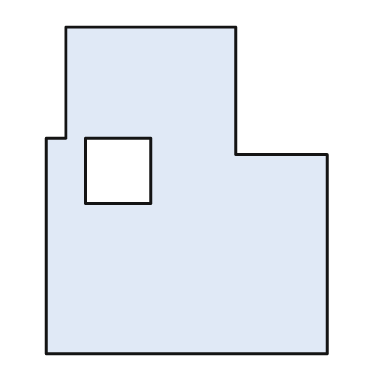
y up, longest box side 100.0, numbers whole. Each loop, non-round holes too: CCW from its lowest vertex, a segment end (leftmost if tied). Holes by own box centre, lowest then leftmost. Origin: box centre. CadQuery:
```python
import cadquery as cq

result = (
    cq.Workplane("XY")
    .moveTo(-43.0, -50.0)
    .lineTo(43.0, -50.0)
    .lineTo(43.0, 11.0)
    .lineTo(15.0, 11.0)
    .lineTo(15.0, 50.0)
    .lineTo(-37.0, 50.0)
    .lineTo(-37.0, 16.0)
    .lineTo(-43.0, 16.0)
    .close()
    .moveTo(-31.0, -4.0)
    .lineTo(-11.0, -4.0)
    .lineTo(-11.0, 16.0)
    .lineTo(-31.0, 16.0)
    .close()
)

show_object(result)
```